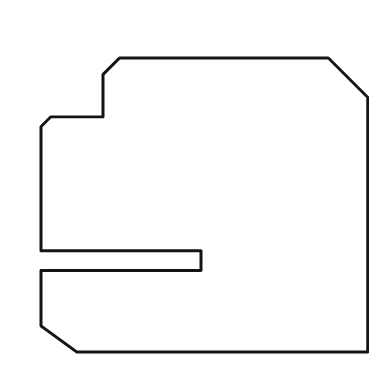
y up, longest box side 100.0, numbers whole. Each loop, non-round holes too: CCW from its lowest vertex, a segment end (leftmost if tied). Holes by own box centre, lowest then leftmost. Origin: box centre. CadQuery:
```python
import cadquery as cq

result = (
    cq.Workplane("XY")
    .moveTo(-39.0, -45.0)
    .lineTo(50.0, -45.0)
    .lineTo(50.0, 33.0)
    .lineTo(38.0, 45.0)
    .lineTo(-26.0, 45.0)
    .lineTo(-31.0, 40.0)
    .lineTo(-31.0, 27.0)
    .lineTo(-47.0, 27.0)
    .lineTo(-50.0, 24.0)
    .lineTo(-50.0, -14.0)
    .lineTo(-1.0, -14.0)
    .lineTo(-1.0, -20.0)
    .lineTo(-50.0, -20.0)
    .lineTo(-50.0, -37.0)
    .close()
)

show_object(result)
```